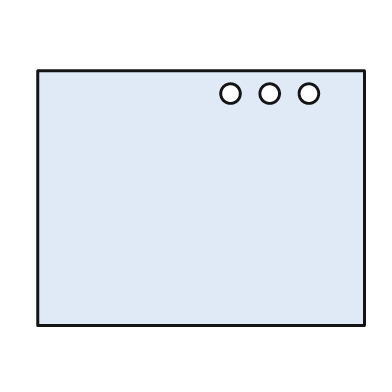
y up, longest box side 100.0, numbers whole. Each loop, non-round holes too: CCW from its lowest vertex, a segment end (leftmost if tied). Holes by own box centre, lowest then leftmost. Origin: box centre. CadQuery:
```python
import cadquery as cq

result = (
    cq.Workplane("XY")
    .moveTo(-50.0, -39.0)
    .lineTo(50.0, -39.0)
    .lineTo(50.0, 39.0)
    .lineTo(-50.0, 39.0)
    .close()
    .moveTo(9.0, 32.0)
    .circle(3.0)
    .moveTo(21.0, 32.0)
    .circle(3.0)
    .moveTo(33.0, 32.0)
    .circle(3.0)
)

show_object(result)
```